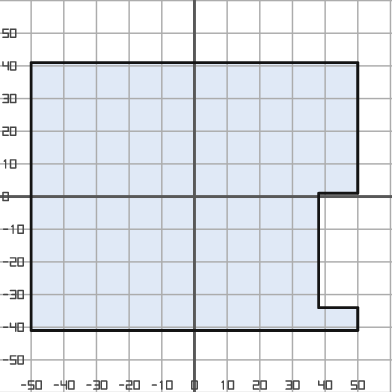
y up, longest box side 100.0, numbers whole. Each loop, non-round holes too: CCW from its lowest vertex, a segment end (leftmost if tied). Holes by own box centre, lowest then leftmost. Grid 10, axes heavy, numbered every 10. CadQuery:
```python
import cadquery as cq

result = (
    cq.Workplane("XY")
    .moveTo(-50.0, -41.0)
    .lineTo(50.0, -41.0)
    .lineTo(50.0, -34.0)
    .lineTo(38.0, -34.0)
    .lineTo(38.0, 1.0)
    .lineTo(50.0, 1.0)
    .lineTo(50.0, 41.0)
    .lineTo(-50.0, 41.0)
    .close()
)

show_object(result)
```